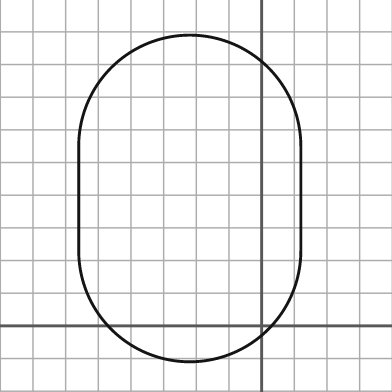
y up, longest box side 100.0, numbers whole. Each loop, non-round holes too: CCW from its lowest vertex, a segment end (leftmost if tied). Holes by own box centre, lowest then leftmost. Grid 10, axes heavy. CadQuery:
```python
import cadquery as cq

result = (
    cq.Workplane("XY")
    .moveTo(-56.0, 23.0)
    .threePointArc((-22.0, -11.0), (12.0, 23.0))
    .lineTo(12.0, 55.0)
    .threePointArc((-22.0, 89.0), (-56.0, 55.0))
    .close()
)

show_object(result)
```